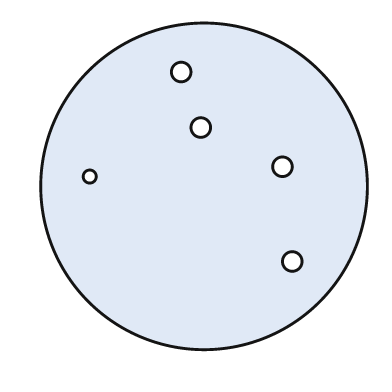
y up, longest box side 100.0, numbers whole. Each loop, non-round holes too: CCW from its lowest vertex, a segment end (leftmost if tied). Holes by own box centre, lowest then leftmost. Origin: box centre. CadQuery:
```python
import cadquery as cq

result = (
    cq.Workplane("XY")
    .moveTo(0.0, 0.0)
    .circle(50.0)
    .moveTo(27.0, -23.0)
    .circle(3.0)
    .moveTo(-35.0, 3.0)
    .circle(2.0)
    .moveTo(24.0, 6.0)
    .circle(3.0)
    .moveTo(-1.0, 18.0)
    .circle(3.0)
    .moveTo(-7.0, 35.0)
    .circle(3.0)
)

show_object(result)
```